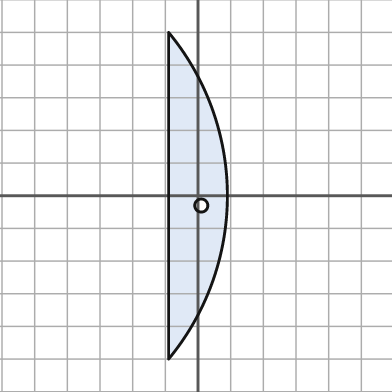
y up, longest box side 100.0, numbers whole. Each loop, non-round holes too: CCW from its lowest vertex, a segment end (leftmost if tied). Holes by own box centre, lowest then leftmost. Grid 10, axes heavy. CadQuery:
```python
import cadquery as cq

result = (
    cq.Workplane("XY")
    .moveTo(-9.0, -50.0)
    .threePointArc((9.0, 0.0), (-9.0, 50.0))
    .close()
    .moveTo(1.0, -3.0)
    .circle(2.0)
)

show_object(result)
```